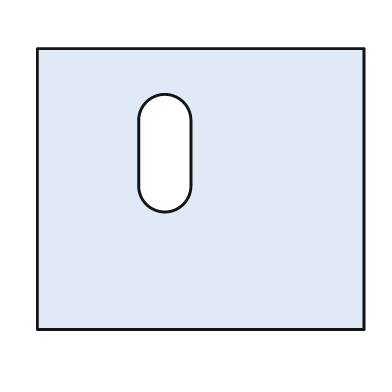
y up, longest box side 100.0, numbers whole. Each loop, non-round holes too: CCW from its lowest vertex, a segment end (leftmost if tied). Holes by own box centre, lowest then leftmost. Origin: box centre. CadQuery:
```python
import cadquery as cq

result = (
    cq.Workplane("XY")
    .moveTo(-50.0, -43.0)
    .lineTo(50.0, -43.0)
    .lineTo(50.0, 43.0)
    .lineTo(-50.0, 43.0)
    .close()
    .moveTo(-19.0, 1.0)
    .threePointArc((-11.0, -7.0), (-3.0, 1.0))
    .lineTo(-3.0, 21.0)
    .threePointArc((-11.0, 29.0), (-19.0, 21.0))
    .close()
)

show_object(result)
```